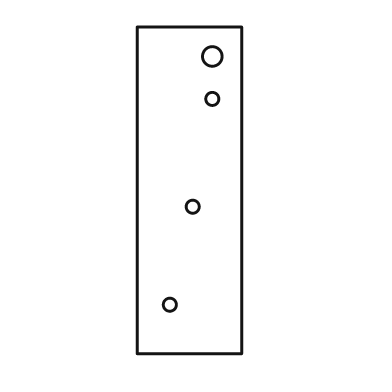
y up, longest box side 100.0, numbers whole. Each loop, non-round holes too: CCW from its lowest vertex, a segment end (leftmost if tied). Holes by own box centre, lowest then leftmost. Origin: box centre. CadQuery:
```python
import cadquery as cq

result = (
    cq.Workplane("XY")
    .moveTo(-16.0, -50.0)
    .lineTo(16.0, -50.0)
    .lineTo(16.0, 50.0)
    .lineTo(-16.0, 50.0)
    .close()
    .moveTo(-6.0, -35.0)
    .circle(2.0)
    .moveTo(1.0, -5.0)
    .circle(2.0)
    .moveTo(7.0, 28.0)
    .circle(2.0)
    .moveTo(7.0, 41.0)
    .circle(3.0)
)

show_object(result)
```